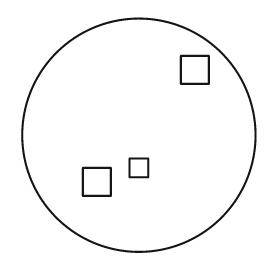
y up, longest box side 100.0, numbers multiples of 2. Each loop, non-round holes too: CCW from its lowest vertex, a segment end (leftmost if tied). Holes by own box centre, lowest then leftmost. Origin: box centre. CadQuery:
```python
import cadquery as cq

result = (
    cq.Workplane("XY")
    .moveTo(0.0, 0.0)
    .circle(50.0)
    .moveTo(-24.0, -26.0)
    .lineTo(-12.0, -26.0)
    .lineTo(-12.0, -14.0)
    .lineTo(-24.0, -14.0)
    .close()
    .moveTo(-4.0, -18.0)
    .lineTo(4.0, -18.0)
    .lineTo(4.0, -10.0)
    .lineTo(-4.0, -10.0)
    .close()
    .moveTo(18.0, 22.0)
    .lineTo(30.0, 22.0)
    .lineTo(30.0, 34.0)
    .lineTo(18.0, 34.0)
    .close()
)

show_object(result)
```